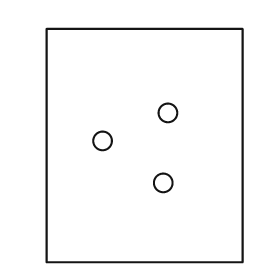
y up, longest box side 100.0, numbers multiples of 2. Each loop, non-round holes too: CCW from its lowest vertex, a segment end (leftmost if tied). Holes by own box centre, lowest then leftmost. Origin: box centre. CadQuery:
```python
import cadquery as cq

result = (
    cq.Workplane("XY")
    .moveTo(-42.0, -50.0)
    .lineTo(42.0, -50.0)
    .lineTo(42.0, 50.0)
    .lineTo(-42.0, 50.0)
    .close()
    .moveTo(8.0, -16.0)
    .circle(4.0)
    .moveTo(-18.0, 2.0)
    .circle(4.0)
    .moveTo(10.0, 14.0)
    .circle(4.0)
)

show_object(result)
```